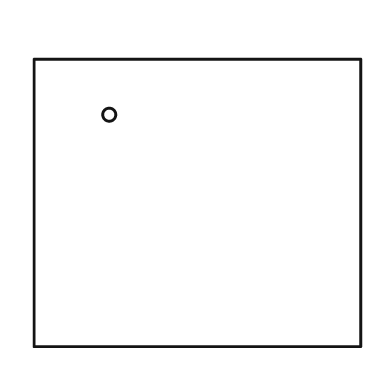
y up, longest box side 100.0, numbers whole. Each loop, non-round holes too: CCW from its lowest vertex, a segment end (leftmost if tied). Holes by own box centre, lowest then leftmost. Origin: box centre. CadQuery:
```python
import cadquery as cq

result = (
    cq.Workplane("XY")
    .moveTo(-50.0, -44.0)
    .lineTo(50.0, -44.0)
    .lineTo(50.0, 44.0)
    .lineTo(-50.0, 44.0)
    .close()
    .moveTo(-27.0, 27.0)
    .circle(2.0)
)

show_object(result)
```